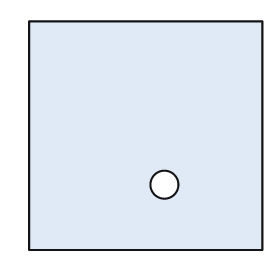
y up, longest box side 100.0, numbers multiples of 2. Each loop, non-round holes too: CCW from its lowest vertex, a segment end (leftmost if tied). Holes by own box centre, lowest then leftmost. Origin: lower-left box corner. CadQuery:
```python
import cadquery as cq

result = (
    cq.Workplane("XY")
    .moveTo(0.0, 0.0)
    .lineTo(100.0, 0.0)
    .lineTo(100.0, 98.0)
    .lineTo(0.0, 98.0)
    .close()
    .moveTo(58.0, 28.0)
    .circle(6.0)
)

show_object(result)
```